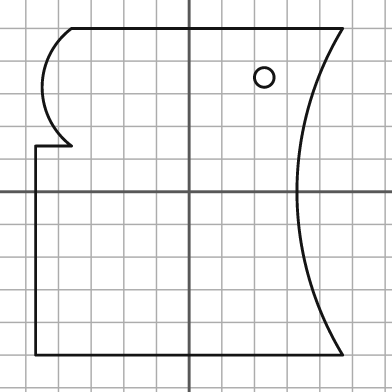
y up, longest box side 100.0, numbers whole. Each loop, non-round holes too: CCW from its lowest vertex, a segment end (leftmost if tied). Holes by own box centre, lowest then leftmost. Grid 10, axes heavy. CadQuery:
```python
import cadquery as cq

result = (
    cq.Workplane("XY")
    .moveTo(-47.0, -50.0)
    .lineTo(47.0, -50.0)
    .threePointArc((33.0, 0.0), (47.0, 50.0))
    .lineTo(-36.0, 50.0)
    .threePointArc((-45.0, 32.0), (-36.0, 14.0))
    .lineTo(-47.0, 14.0)
    .close()
    .moveTo(23.0, 35.0)
    .circle(3.0)
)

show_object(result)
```